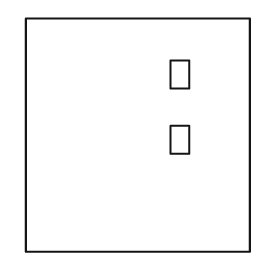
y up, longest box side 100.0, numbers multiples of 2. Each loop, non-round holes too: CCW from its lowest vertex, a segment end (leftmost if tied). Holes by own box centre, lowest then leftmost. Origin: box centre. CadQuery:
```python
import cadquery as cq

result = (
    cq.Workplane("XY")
    .moveTo(-48.0, -50.0)
    .lineTo(48.0, -50.0)
    .lineTo(48.0, 50.0)
    .lineTo(-48.0, 50.0)
    .close()
    .moveTo(14.0, -8.0)
    .lineTo(22.0, -8.0)
    .lineTo(22.0, 4.0)
    .lineTo(14.0, 4.0)
    .close()
    .moveTo(14.0, 20.0)
    .lineTo(22.0, 20.0)
    .lineTo(22.0, 32.0)
    .lineTo(14.0, 32.0)
    .close()
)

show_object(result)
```